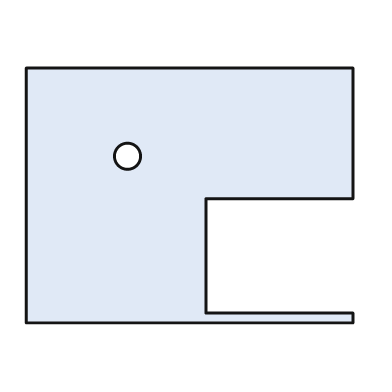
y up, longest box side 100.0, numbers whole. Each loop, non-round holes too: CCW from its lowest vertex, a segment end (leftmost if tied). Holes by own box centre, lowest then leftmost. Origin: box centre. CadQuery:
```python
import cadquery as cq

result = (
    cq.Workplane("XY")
    .moveTo(-50.0, -39.0)
    .lineTo(50.0, -39.0)
    .lineTo(50.0, -36.0)
    .lineTo(5.0, -36.0)
    .lineTo(5.0, -1.0)
    .lineTo(50.0, -1.0)
    .lineTo(50.0, 39.0)
    .lineTo(-50.0, 39.0)
    .close()
    .moveTo(-19.0, 12.0)
    .circle(4.0)
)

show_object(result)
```